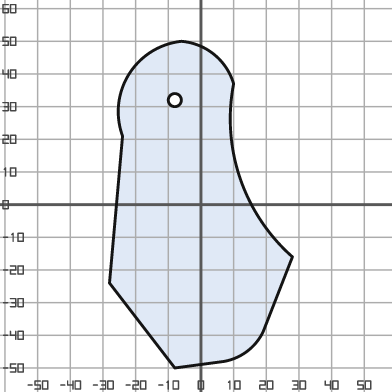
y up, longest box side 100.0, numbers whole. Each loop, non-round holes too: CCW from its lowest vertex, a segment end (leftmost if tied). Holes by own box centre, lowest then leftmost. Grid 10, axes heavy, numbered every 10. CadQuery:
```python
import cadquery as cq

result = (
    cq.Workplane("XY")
    .moveTo(-8.0, -50.0)
    .lineTo(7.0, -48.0)
    .threePointArc((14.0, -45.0), (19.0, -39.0))
    .lineTo(28.0, -16.0)
    .threePointArc((12.0, 8.0), (10.0, 37.0))
    .threePointArc((4.0, 46.0), (-6.0, 50.0))
    .threePointArc((-22.0, 40.0), (-24.0, 21.0))
    .lineTo(-28.0, -24.0)
    .close()
    .moveTo(-8.0, 32.0)
    .circle(2.0)
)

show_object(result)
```